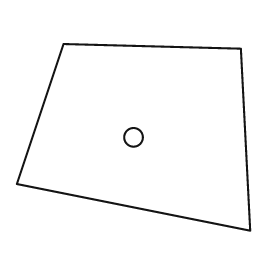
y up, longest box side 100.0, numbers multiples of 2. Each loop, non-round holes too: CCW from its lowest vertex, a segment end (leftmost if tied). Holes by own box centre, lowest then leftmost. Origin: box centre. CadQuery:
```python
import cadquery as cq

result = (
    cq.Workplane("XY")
    .moveTo(50.0, -40.0)
    .lineTo(46.0, 38.0)
    .lineTo(-30.0, 40.0)
    .lineTo(-50.0, -20.0)
    .close()
    .moveTo(0.0, 0.0)
    .circle(4.0)
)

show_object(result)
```